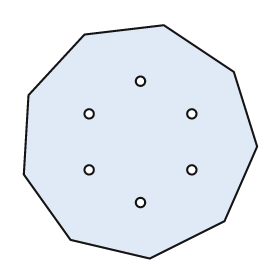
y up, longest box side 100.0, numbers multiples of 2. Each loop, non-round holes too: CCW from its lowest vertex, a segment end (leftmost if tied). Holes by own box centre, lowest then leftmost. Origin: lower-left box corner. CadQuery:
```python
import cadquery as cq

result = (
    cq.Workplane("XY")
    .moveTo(54.0, 0.0)
    .lineTo(86.0, 16.0)
    .lineTo(100.0, 48.0)
    .lineTo(90.0, 80.0)
    .lineTo(60.0, 100.0)
    .lineTo(26.0, 96.0)
    .lineTo(2.0, 70.0)
    .lineTo(0.0, 36.0)
    .lineTo(20.0, 8.0)
    .close()
    .moveTo(50.0, 24.0)
    .circle(2.0)
    .moveTo(28.0, 38.0)
    .circle(2.0)
    .moveTo(72.0, 38.0)
    .circle(2.0)
    .moveTo(28.0, 62.0)
    .circle(2.0)
    .moveTo(72.0, 62.0)
    .circle(2.0)
    .moveTo(50.0, 76.0)
    .circle(2.0)
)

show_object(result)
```